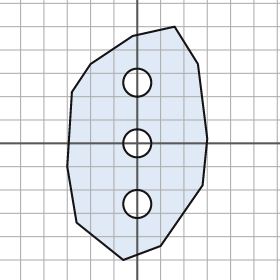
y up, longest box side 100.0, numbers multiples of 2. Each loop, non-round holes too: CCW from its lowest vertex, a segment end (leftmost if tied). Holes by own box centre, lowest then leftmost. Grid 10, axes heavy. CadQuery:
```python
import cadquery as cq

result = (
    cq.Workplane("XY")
    .moveTo(-6.0, -50.0)
    .lineTo(10.0, -44.0)
    .lineTo(28.0, -18.0)
    .lineTo(30.0, 2.0)
    .lineTo(26.0, 34.0)
    .lineTo(16.0, 50.0)
    .lineTo(-2.0, 46.0)
    .lineTo(-20.0, 34.0)
    .lineTo(-28.0, 22.0)
    .lineTo(-30.0, -10.0)
    .lineTo(-26.0, -34.0)
    .close()
    .moveTo(0.0, -26.0)
    .circle(6.0)
    .moveTo(0.0, 0.0)
    .circle(6.0)
    .moveTo(0.0, 26.0)
    .circle(6.0)
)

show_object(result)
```